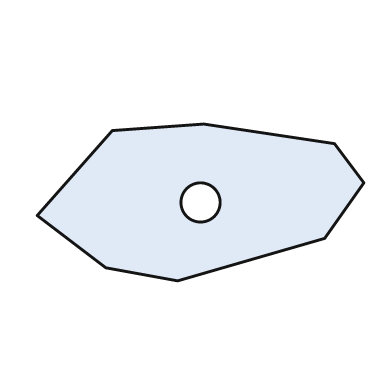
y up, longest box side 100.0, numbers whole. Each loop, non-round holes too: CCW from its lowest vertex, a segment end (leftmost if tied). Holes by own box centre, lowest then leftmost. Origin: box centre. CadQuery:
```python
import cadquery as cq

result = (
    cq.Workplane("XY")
    .moveTo(-7.0, -24.0)
    .lineTo(38.0, -11.0)
    .lineTo(50.0, 6.0)
    .lineTo(41.0, 18.0)
    .lineTo(1.0, 24.0)
    .lineTo(-27.0, 22.0)
    .lineTo(-50.0, -4.0)
    .lineTo(-29.0, -20.0)
    .close()
    .moveTo(0.0, 0.0)
    .circle(6.0)
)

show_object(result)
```